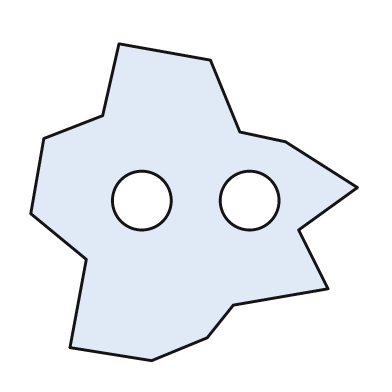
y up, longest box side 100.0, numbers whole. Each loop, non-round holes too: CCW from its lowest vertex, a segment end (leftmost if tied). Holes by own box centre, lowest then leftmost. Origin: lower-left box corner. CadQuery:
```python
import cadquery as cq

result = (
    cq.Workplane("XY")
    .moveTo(37.0, 0.0)
    .lineTo(54.0, 7.0)
    .lineTo(62.0, 17.0)
    .lineTo(91.0, 22.0)
    .lineTo(82.0, 40.0)
    .lineTo(100.0, 53.0)
    .lineTo(78.0, 67.0)
    .lineTo(64.0, 70.0)
    .lineTo(55.0, 92.0)
    .lineTo(27.0, 97.0)
    .lineTo(22.0, 75.0)
    .lineTo(4.0, 68.0)
    .lineTo(0.0, 45.0)
    .lineTo(17.0, 31.0)
    .lineTo(12.0, 4.0)
    .close()
    .moveTo(34.0, 49.0)
    .circle(9.0)
    .moveTo(67.0, 49.0)
    .circle(9.0)
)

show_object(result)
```